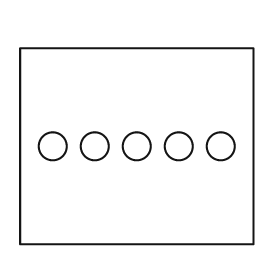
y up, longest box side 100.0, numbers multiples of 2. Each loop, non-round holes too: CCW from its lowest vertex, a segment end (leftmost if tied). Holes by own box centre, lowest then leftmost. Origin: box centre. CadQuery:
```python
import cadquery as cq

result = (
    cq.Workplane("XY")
    .moveTo(-50.0, -42.0)
    .lineTo(50.0, -42.0)
    .lineTo(50.0, 42.0)
    .lineTo(-50.0, 42.0)
    .close()
    .moveTo(-36.0, 0.0)
    .circle(6.0)
    .moveTo(-18.0, 0.0)
    .circle(6.0)
    .moveTo(0.0, 0.0)
    .circle(6.0)
    .moveTo(18.0, 0.0)
    .circle(6.0)
    .moveTo(36.0, 0.0)
    .circle(6.0)
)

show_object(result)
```